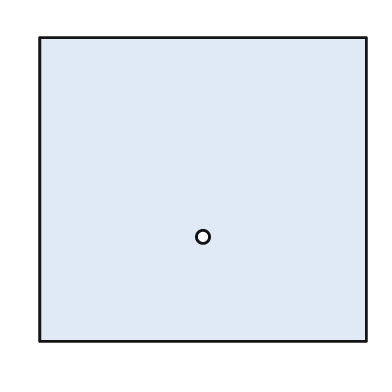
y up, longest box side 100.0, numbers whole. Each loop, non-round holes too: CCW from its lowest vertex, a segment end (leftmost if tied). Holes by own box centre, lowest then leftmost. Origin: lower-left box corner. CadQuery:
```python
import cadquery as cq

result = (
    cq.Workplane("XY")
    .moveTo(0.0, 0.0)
    .lineTo(100.0, 0.0)
    .lineTo(100.0, 93.0)
    .lineTo(0.0, 93.0)
    .close()
    .moveTo(50.0, 32.0)
    .circle(2.0)
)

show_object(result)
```